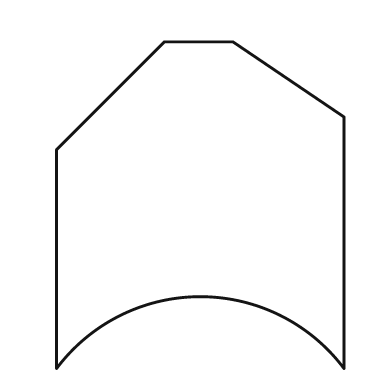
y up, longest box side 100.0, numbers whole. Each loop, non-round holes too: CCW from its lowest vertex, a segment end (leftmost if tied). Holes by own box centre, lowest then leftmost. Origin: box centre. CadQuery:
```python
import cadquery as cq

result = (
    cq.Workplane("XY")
    .moveTo(-44.0, -50.0)
    .threePointArc((0.0, -28.0), (44.0, -50.0))
    .lineTo(44.0, 27.0)
    .lineTo(10.0, 50.0)
    .lineTo(-11.0, 50.0)
    .lineTo(-44.0, 17.0)
    .close()
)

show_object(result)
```